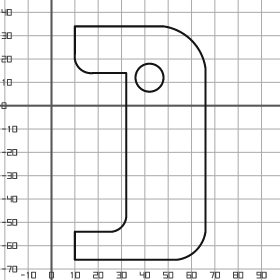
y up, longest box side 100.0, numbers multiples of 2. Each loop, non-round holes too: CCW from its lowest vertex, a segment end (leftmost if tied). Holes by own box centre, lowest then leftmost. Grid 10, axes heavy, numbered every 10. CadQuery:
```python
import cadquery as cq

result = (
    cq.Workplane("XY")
    .moveTo(10.0, -66.0)
    .lineTo(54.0, -66.0)
    .threePointArc((62.0, -62.0), (66.0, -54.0))
    .lineTo(66.0, 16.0)
    .threePointArc((60.0, 28.0), (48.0, 34.0))
    .lineTo(10.0, 34.0)
    .lineTo(10.0, 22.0)
    .threePointArc((12.0, 16.0), (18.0, 14.0))
    .lineTo(32.0, 14.0)
    .lineTo(32.0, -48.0)
    .threePointArc((30.0, -52.0), (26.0, -54.0))
    .lineTo(10.0, -54.0)
    .close()
    .moveTo(42.0, 12.0)
    .circle(6.0)
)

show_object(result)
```